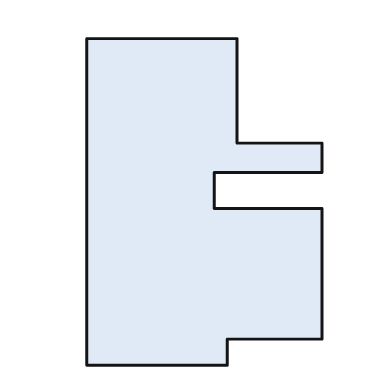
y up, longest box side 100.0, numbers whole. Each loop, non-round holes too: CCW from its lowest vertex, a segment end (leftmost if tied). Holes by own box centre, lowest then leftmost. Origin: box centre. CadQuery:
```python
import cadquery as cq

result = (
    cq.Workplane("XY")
    .moveTo(-36.0, -50.0)
    .lineTo(7.0, -50.0)
    .lineTo(7.0, -42.0)
    .lineTo(36.0, -42.0)
    .lineTo(36.0, -2.0)
    .lineTo(3.0, -2.0)
    .lineTo(3.0, 9.0)
    .lineTo(36.0, 9.0)
    .lineTo(36.0, 18.0)
    .lineTo(10.0, 18.0)
    .lineTo(10.0, 50.0)
    .lineTo(-36.0, 50.0)
    .close()
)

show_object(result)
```